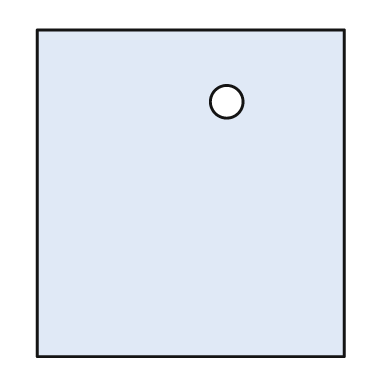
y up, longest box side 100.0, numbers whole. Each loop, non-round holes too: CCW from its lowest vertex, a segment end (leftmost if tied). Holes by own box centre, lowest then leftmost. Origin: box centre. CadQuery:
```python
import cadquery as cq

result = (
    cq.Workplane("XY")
    .moveTo(-47.0, -50.0)
    .lineTo(47.0, -50.0)
    .lineTo(47.0, 50.0)
    .lineTo(-47.0, 50.0)
    .close()
    .moveTo(11.0, 28.0)
    .circle(5.0)
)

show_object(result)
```